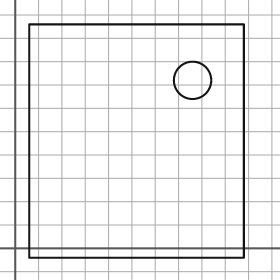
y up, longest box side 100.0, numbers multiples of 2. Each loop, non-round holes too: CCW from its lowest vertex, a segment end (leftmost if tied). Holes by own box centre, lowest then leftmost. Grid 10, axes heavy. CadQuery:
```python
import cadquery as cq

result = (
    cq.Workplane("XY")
    .moveTo(6.0, -4.0)
    .lineTo(98.0, -4.0)
    .lineTo(98.0, 96.0)
    .lineTo(6.0, 96.0)
    .close()
    .moveTo(76.0, 72.0)
    .circle(8.0)
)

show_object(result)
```